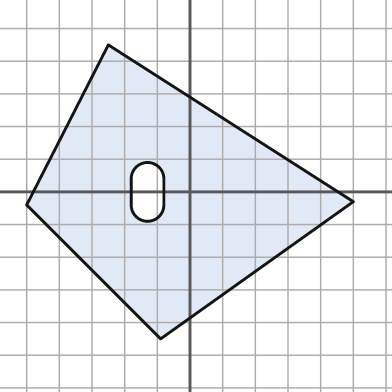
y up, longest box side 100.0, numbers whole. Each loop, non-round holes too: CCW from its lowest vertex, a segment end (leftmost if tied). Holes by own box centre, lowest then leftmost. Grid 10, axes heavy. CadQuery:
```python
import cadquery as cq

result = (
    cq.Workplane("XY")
    .moveTo(-9.0, -45.0)
    .lineTo(50.0, -3.0)
    .lineTo(-25.0, 45.0)
    .lineTo(-50.0, -4.0)
    .close()
    .moveTo(-18.0, -4.0)
    .threePointArc((-13.0, -9.0), (-8.0, -4.0))
    .lineTo(-8.0, 4.0)
    .threePointArc((-13.0, 9.0), (-18.0, 4.0))
    .close()
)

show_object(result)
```